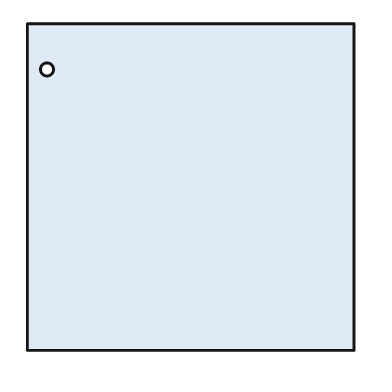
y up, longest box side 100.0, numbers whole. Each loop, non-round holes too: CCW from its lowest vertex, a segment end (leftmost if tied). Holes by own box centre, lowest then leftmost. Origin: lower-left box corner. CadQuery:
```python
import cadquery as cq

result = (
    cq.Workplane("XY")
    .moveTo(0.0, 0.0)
    .lineTo(100.0, 0.0)
    .lineTo(100.0, 100.0)
    .lineTo(0.0, 100.0)
    .close()
    .moveTo(6.0, 86.0)
    .circle(2.0)
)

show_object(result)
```